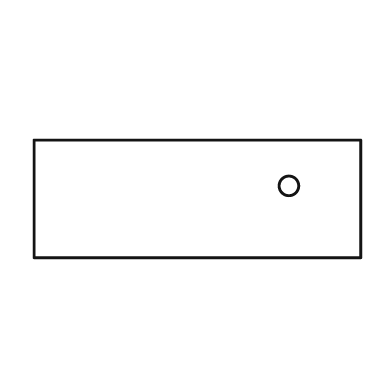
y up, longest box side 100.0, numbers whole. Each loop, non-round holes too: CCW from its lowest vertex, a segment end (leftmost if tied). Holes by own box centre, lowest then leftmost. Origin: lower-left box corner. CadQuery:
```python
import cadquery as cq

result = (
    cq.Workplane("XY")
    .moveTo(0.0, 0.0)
    .lineTo(100.0, 0.0)
    .lineTo(100.0, 36.0)
    .lineTo(0.0, 36.0)
    .close()
    .moveTo(78.0, 22.0)
    .circle(3.0)
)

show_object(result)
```